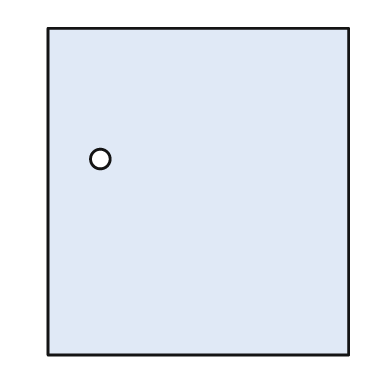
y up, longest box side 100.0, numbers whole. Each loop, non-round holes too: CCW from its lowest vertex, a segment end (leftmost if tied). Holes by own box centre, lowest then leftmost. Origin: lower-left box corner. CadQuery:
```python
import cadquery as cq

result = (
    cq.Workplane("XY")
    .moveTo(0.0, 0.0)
    .lineTo(92.0, 0.0)
    .lineTo(92.0, 100.0)
    .lineTo(0.0, 100.0)
    .close()
    .moveTo(16.0, 60.0)
    .circle(3.0)
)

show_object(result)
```